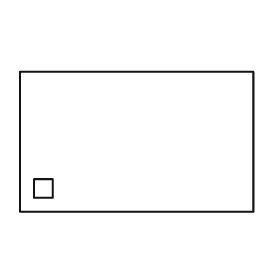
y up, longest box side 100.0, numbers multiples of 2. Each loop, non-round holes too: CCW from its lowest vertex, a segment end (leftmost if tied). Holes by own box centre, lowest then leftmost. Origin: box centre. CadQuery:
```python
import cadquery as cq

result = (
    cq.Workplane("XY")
    .moveTo(-50.0, -30.0)
    .lineTo(50.0, -30.0)
    .lineTo(50.0, 30.0)
    .lineTo(-50.0, 30.0)
    .close()
    .moveTo(-44.0, -24.0)
    .lineTo(-36.0, -24.0)
    .lineTo(-36.0, -16.0)
    .lineTo(-44.0, -16.0)
    .close()
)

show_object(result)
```